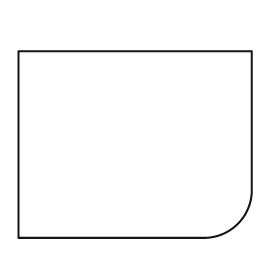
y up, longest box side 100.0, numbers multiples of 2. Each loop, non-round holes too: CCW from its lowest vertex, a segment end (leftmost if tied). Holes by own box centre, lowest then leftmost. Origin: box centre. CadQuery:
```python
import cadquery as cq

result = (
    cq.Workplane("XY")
    .moveTo(-50.0, -40.0)
    .lineTo(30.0, -40.0)
    .threePointArc((44.0, -34.0), (50.0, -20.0))
    .lineTo(50.0, 40.0)
    .lineTo(-50.0, 40.0)
    .close()
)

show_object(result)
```